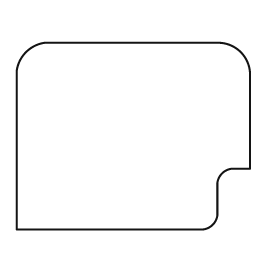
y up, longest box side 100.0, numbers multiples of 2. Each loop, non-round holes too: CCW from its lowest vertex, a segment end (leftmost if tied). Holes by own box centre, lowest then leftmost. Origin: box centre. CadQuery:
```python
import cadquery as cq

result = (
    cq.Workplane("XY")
    .moveTo(-50.0, -40.0)
    .lineTo(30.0, -40.0)
    .threePointArc((34.0, -38.0), (36.0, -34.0))
    .lineTo(36.0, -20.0)
    .threePointArc((38.0, -16.0), (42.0, -14.0))
    .lineTo(50.0, -14.0)
    .lineTo(50.0, 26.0)
    .threePointArc((46.0, 36.0), (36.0, 40.0))
    .lineTo(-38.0, 40.0)
    .threePointArc((-46.0, 36.0), (-50.0, 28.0))
    .close()
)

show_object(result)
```